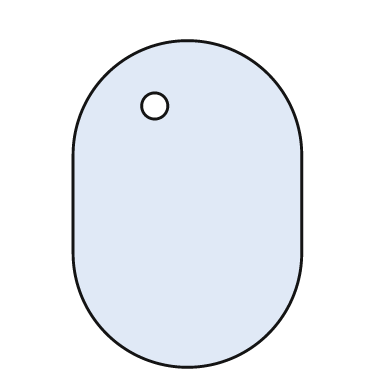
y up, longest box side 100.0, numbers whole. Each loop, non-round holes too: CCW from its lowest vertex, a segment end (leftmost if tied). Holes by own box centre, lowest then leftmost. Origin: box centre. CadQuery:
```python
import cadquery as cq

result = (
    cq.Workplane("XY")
    .moveTo(-35.0, -15.0)
    .threePointArc((0.0, -50.0), (35.0, -15.0))
    .lineTo(35.0, 15.0)
    .threePointArc((0.0, 50.0), (-35.0, 15.0))
    .close()
    .moveTo(-10.0, 30.0)
    .circle(4.0)
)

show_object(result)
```